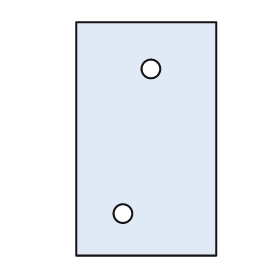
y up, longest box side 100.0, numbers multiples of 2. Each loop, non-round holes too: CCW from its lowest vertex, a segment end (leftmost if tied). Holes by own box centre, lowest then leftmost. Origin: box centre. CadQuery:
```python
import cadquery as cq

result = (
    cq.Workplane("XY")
    .moveTo(-30.0, -50.0)
    .lineTo(30.0, -50.0)
    .lineTo(30.0, 50.0)
    .lineTo(-30.0, 50.0)
    .close()
    .moveTo(-10.0, -32.0)
    .circle(4.0)
    .moveTo(2.0, 30.0)
    .circle(4.0)
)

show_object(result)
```